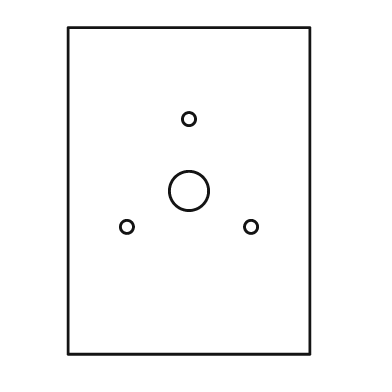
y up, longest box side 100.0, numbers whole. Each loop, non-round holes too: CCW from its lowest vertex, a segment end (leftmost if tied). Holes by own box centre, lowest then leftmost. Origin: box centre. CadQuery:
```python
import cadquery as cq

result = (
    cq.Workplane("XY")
    .moveTo(-37.0, -50.0)
    .lineTo(37.0, -50.0)
    .lineTo(37.0, 50.0)
    .lineTo(-37.0, 50.0)
    .close()
    .moveTo(-19.0, -11.0)
    .circle(2.0)
    .moveTo(19.0, -11.0)
    .circle(2.0)
    .moveTo(0.0, 0.0)
    .circle(6.0)
    .moveTo(0.0, 22.0)
    .circle(2.0)
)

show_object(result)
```